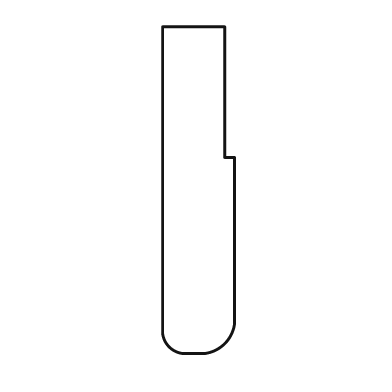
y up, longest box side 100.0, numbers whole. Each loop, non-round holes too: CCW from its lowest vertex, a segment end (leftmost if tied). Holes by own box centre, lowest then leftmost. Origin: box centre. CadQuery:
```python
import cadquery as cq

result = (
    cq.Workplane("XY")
    .moveTo(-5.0, -50.0)
    .lineTo(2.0, -50.0)
    .threePointArc((8.0, -47.0), (11.0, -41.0))
    .lineTo(11.0, 10.0)
    .lineTo(8.0, 10.0)
    .lineTo(8.0, 50.0)
    .lineTo(-11.0, 50.0)
    .lineTo(-11.0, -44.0)
    .threePointArc((-9.0, -48.0), (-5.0, -50.0))
    .close()
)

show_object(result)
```